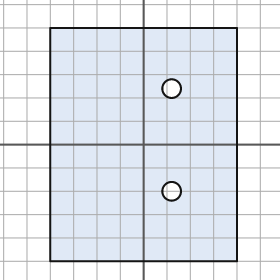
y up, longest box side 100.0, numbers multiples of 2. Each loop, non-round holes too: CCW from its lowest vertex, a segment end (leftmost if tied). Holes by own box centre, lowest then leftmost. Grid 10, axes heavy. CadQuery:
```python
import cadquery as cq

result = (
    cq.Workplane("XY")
    .moveTo(-40.0, -50.0)
    .lineTo(40.0, -50.0)
    .lineTo(40.0, 50.0)
    .lineTo(-40.0, 50.0)
    .close()
    .moveTo(12.0, -20.0)
    .circle(4.0)
    .moveTo(12.0, 24.0)
    .circle(4.0)
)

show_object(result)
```